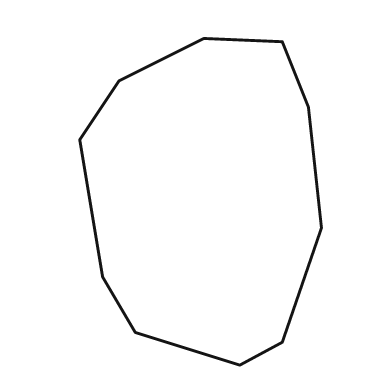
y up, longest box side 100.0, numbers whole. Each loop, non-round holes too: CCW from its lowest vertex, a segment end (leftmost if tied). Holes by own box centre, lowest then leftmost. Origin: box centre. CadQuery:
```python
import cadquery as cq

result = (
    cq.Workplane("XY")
    .moveTo(12.0, -50.0)
    .lineTo(25.0, -43.0)
    .lineTo(37.0, -8.0)
    .lineTo(33.0, 29.0)
    .lineTo(25.0, 49.0)
    .lineTo(1.0, 50.0)
    .lineTo(-25.0, 37.0)
    .lineTo(-37.0, 19.0)
    .lineTo(-30.0, -23.0)
    .lineTo(-20.0, -40.0)
    .close()
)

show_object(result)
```